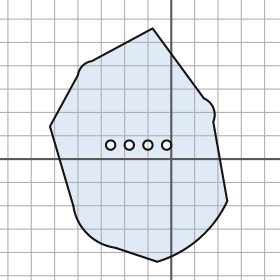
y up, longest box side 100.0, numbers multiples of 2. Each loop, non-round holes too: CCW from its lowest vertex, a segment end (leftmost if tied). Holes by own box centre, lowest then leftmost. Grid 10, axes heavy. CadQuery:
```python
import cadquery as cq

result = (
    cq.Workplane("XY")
    .moveTo(-6.0, -44.0)
    .threePointArc((12.0, -34.0), (24.0, -18.0))
    .lineTo(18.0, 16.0)
    .threePointArc((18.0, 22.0), (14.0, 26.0))
    .lineTo(-8.0, 56.0)
    .lineTo(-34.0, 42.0)
    .threePointArc((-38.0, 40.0), (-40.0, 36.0))
    .lineTo(-52.0, 14.0)
    .lineTo(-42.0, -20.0)
    .threePointArc((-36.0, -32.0), (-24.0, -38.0))
    .close()
    .moveTo(-26.0, 6.0)
    .circle(2.0)
    .moveTo(-18.0, 6.0)
    .circle(2.0)
    .moveTo(-10.0, 6.0)
    .circle(2.0)
    .moveTo(-2.0, 6.0)
    .circle(2.0)
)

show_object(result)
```